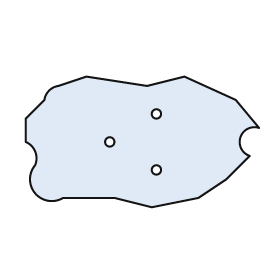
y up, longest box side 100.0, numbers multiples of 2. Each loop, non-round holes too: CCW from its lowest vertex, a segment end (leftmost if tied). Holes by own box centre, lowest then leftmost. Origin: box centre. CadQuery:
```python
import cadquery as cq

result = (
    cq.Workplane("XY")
    .moveTo(4.0, -28.0)
    .lineTo(24.0, -24.0)
    .lineTo(36.0, -16.0)
    .lineTo(46.0, -6.0)
    .threePointArc((42.0, 2.0), (50.0, 6.0))
    .lineTo(40.0, 18.0)
    .lineTo(18.0, 28.0)
    .lineTo(2.0, 24.0)
    .lineTo(-24.0, 28.0)
    .lineTo(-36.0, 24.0)
    .threePointArc((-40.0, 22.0), (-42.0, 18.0))
    .lineTo(-50.0, 10.0)
    .lineTo(-50.0, 0.0)
    .threePointArc((-46.0, -4.0), (-46.0, -10.0))
    .threePointArc((-46.0, -22.0), (-34.0, -24.0))
    .lineTo(-12.0, -24.0)
    .close()
    .moveTo(6.0, -12.0)
    .circle(2.0)
    .moveTo(-14.0, 0.0)
    .circle(2.0)
    .moveTo(6.0, 12.0)
    .circle(2.0)
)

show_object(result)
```